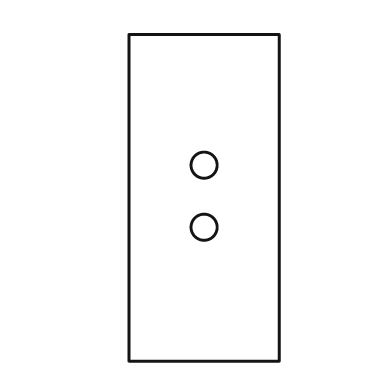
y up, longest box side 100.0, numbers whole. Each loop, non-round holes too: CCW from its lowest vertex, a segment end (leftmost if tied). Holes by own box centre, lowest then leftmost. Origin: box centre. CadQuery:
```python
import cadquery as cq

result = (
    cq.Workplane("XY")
    .moveTo(-23.0, -50.0)
    .lineTo(23.0, -50.0)
    .lineTo(23.0, 50.0)
    .lineTo(-23.0, 50.0)
    .close()
    .moveTo(0.0, -9.0)
    .circle(4.0)
    .moveTo(0.0, 10.0)
    .circle(4.0)
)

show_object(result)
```